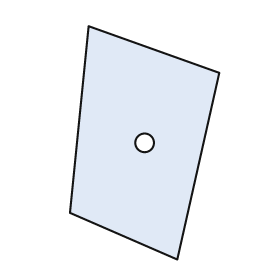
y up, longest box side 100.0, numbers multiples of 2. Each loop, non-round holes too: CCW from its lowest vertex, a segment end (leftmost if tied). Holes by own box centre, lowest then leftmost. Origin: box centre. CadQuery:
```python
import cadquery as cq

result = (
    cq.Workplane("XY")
    .moveTo(14.0, -50.0)
    .lineTo(32.0, 30.0)
    .lineTo(-24.0, 50.0)
    .lineTo(-32.0, -30.0)
    .close()
    .moveTo(0.0, 0.0)
    .circle(4.0)
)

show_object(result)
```